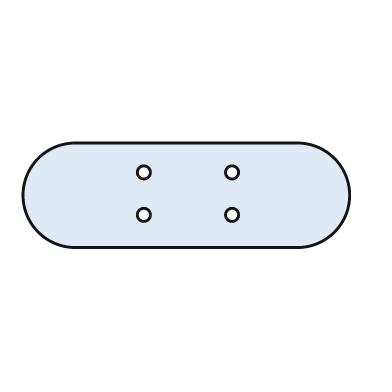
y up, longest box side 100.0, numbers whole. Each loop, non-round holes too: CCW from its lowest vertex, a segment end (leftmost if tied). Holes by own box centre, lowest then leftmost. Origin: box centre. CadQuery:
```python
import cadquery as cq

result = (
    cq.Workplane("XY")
    .moveTo(-34.0, -16.0)
    .lineTo(34.0, -16.0)
    .threePointArc((50.0, 0.0), (34.0, 16.0))
    .lineTo(-34.0, 16.0)
    .threePointArc((-50.0, 0.0), (-34.0, -16.0))
    .close()
    .moveTo(-13.0, -6.0)
    .circle(2.0)
    .moveTo(14.0, -6.0)
    .circle(2.0)
    .moveTo(-13.0, 7.0)
    .circle(2.0)
    .moveTo(14.0, 7.0)
    .circle(2.0)
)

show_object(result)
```